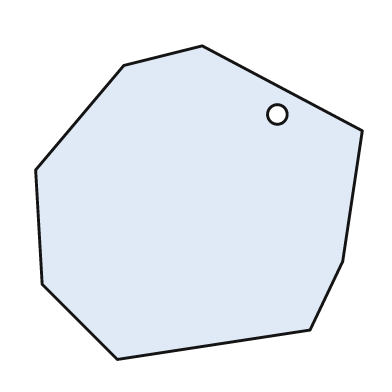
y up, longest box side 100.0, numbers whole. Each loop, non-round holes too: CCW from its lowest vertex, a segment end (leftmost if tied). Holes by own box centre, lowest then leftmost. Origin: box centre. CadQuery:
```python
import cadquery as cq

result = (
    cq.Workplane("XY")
    .moveTo(-25.0, -48.0)
    .lineTo(34.0, -39.0)
    .lineTo(44.0, -18.0)
    .lineTo(50.0, 22.0)
    .lineTo(1.0, 48.0)
    .lineTo(-23.0, 42.0)
    .lineTo(-50.0, 10.0)
    .lineTo(-48.0, -25.0)
    .close()
    .moveTo(24.0, 27.0)
    .circle(3.0)
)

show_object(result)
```